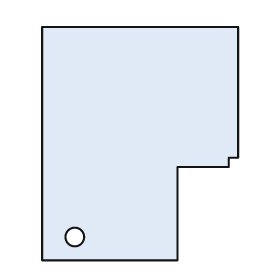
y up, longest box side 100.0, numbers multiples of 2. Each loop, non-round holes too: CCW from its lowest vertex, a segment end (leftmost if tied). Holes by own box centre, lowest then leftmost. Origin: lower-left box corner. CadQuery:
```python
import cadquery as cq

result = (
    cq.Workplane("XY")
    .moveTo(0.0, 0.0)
    .lineTo(58.0, 0.0)
    .lineTo(58.0, 40.0)
    .lineTo(80.0, 40.0)
    .lineTo(80.0, 44.0)
    .lineTo(84.0, 44.0)
    .lineTo(84.0, 100.0)
    .lineTo(0.0, 100.0)
    .close()
    .moveTo(14.0, 10.0)
    .circle(4.0)
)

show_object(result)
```